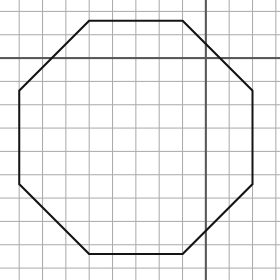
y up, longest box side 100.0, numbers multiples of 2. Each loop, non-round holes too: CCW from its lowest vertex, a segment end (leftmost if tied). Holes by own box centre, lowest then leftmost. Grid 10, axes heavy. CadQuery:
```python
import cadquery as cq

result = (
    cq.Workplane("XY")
    .moveTo(-50.0, -84.0)
    .lineTo(-10.0, -84.0)
    .lineTo(20.0, -54.0)
    .lineTo(20.0, -14.0)
    .lineTo(-10.0, 16.0)
    .lineTo(-50.0, 16.0)
    .lineTo(-80.0, -14.0)
    .lineTo(-80.0, -54.0)
    .close()
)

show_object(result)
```